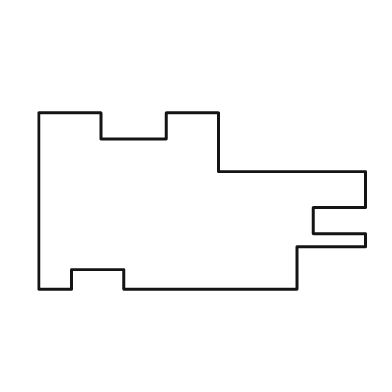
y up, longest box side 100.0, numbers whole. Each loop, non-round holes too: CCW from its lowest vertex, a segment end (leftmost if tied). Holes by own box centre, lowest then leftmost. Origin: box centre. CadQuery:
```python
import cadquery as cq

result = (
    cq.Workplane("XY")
    .moveTo(-50.0, -27.0)
    .lineTo(-40.0, -27.0)
    .lineTo(-40.0, -21.0)
    .lineTo(-24.0, -21.0)
    .lineTo(-24.0, -27.0)
    .lineTo(29.0, -27.0)
    .lineTo(29.0, -14.0)
    .lineTo(50.0, -14.0)
    .lineTo(50.0, -10.0)
    .lineTo(34.0, -10.0)
    .lineTo(34.0, -2.0)
    .lineTo(50.0, -2.0)
    .lineTo(50.0, 9.0)
    .lineTo(5.0, 9.0)
    .lineTo(5.0, 27.0)
    .lineTo(-11.0, 27.0)
    .lineTo(-11.0, 19.0)
    .lineTo(-31.0, 19.0)
    .lineTo(-31.0, 27.0)
    .lineTo(-50.0, 27.0)
    .close()
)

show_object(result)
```